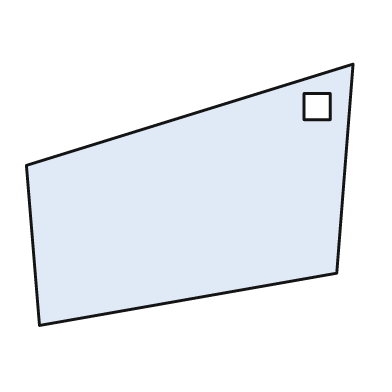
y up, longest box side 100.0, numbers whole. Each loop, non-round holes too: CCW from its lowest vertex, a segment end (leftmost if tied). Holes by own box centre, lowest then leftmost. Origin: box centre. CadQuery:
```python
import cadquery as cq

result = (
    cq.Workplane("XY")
    .moveTo(-46.0, -40.0)
    .lineTo(45.0, -24.0)
    .lineTo(50.0, 40.0)
    .lineTo(-50.0, 9.0)
    .close()
    .moveTo(35.0, 23.0)
    .lineTo(43.0, 23.0)
    .lineTo(43.0, 31.0)
    .lineTo(35.0, 31.0)
    .close()
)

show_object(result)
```